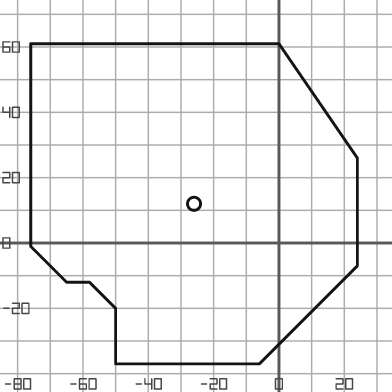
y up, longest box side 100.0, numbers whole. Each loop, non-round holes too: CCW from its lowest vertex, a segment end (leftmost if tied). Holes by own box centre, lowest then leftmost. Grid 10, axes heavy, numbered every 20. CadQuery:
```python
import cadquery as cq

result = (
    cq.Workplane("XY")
    .moveTo(-50.0, -37.0)
    .lineTo(-6.0, -37.0)
    .lineTo(24.0, -7.0)
    .lineTo(24.0, 26.0)
    .lineTo(0.0, 61.0)
    .lineTo(-76.0, 61.0)
    .lineTo(-76.0, -1.0)
    .lineTo(-65.0, -12.0)
    .lineTo(-58.0, -12.0)
    .lineTo(-50.0, -20.0)
    .close()
    .moveTo(-26.0, 12.0)
    .circle(2.0)
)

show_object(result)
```